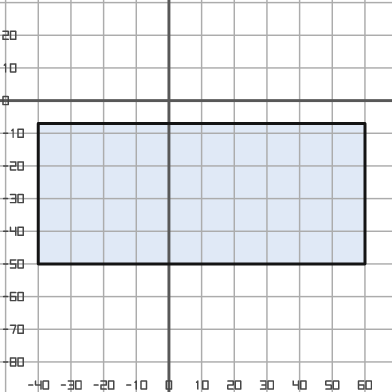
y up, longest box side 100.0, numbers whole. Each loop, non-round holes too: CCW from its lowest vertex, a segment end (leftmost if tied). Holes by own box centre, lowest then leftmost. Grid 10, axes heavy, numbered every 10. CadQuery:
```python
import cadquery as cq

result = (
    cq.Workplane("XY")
    .moveTo(-40.0, -50.0)
    .lineTo(60.0, -50.0)
    .lineTo(60.0, -7.0)
    .lineTo(-40.0, -7.0)
    .close()
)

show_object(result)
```